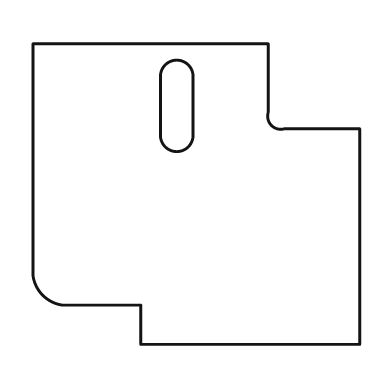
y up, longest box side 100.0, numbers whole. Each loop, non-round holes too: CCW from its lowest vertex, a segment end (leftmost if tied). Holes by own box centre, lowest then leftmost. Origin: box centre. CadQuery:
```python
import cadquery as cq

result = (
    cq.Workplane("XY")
    .moveTo(-17.0, -46.0)
    .lineTo(50.0, -46.0)
    .lineTo(50.0, 20.0)
    .lineTo(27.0, 20.0)
    .threePointArc((23.0, 21.0), (22.0, 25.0))
    .lineTo(22.0, 46.0)
    .lineTo(-50.0, 46.0)
    .lineTo(-50.0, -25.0)
    .threePointArc((-47.0, -31.0), (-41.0, -34.0))
    .lineTo(-17.0, -34.0)
    .close()
    .moveTo(-11.0, 18.0)
    .threePointArc((-6.0, 13.0), (-1.0, 18.0))
    .lineTo(-1.0, 36.0)
    .threePointArc((-6.0, 41.0), (-11.0, 36.0))
    .close()
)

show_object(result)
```